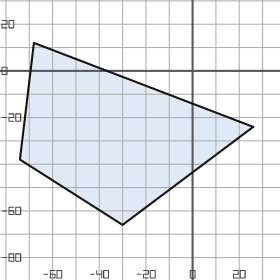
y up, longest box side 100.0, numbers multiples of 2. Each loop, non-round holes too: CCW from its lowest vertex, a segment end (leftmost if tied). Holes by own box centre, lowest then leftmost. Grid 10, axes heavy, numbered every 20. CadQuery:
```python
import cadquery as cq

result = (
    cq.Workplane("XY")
    .moveTo(-30.0, -66.0)
    .lineTo(26.0, -24.0)
    .lineTo(-68.0, 12.0)
    .lineTo(-74.0, -38.0)
    .close()
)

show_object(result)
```